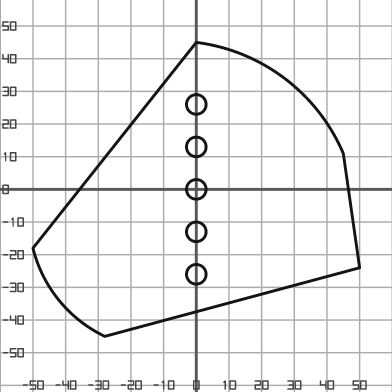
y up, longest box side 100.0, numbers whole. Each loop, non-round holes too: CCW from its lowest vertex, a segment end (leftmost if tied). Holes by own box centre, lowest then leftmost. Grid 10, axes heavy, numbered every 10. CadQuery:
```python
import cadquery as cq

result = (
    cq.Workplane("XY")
    .moveTo(-28.0, -45.0)
    .lineTo(50.0, -24.0)
    .lineTo(45.0, 11.0)
    .threePointArc((27.0, 34.0), (0.0, 45.0))
    .lineTo(-50.0, -18.0)
    .threePointArc((-42.0, -34.0), (-28.0, -45.0))
    .close()
    .moveTo(0.0, -26.0)
    .circle(3.0)
    .moveTo(0.0, -13.0)
    .circle(3.0)
    .moveTo(0.0, 0.0)
    .circle(3.0)
    .moveTo(0.0, 13.0)
    .circle(3.0)
    .moveTo(0.0, 26.0)
    .circle(3.0)
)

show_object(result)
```